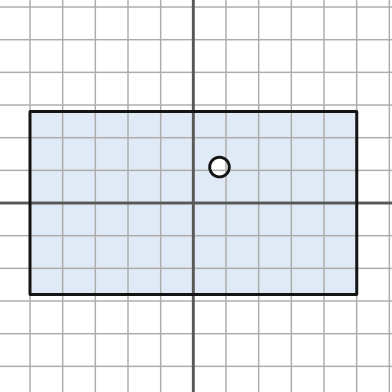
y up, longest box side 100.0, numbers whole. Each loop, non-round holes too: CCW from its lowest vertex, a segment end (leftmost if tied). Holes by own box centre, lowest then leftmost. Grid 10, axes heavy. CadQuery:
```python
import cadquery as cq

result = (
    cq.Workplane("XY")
    .moveTo(-50.0, -28.0)
    .lineTo(50.0, -28.0)
    .lineTo(50.0, 28.0)
    .lineTo(-50.0, 28.0)
    .close()
    .moveTo(8.0, 11.0)
    .circle(3.0)
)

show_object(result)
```